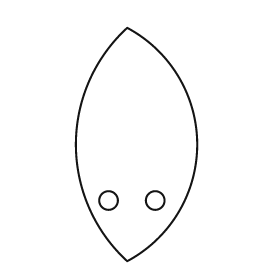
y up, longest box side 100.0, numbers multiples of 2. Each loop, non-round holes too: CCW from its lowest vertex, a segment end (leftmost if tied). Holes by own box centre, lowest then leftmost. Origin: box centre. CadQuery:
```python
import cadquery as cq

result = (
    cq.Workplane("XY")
    .moveTo(-4.0, -50.0)
    .threePointArc((26.0, 0.0), (-4.0, 50.0))
    .threePointArc((-26.0, 0.0), (-4.0, -50.0))
    .close()
    .moveTo(-12.0, -24.0)
    .circle(4.0)
    .moveTo(8.0, -24.0)
    .circle(4.0)
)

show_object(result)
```